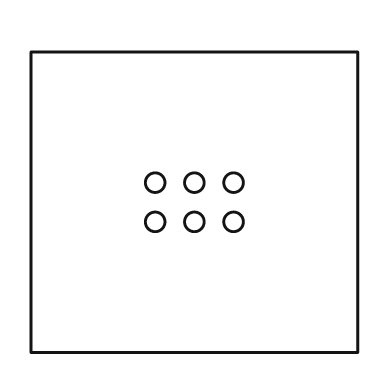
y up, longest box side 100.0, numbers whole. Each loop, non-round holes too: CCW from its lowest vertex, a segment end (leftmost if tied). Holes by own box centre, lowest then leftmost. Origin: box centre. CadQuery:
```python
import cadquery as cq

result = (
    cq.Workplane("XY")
    .moveTo(-50.0, -46.0)
    .lineTo(50.0, -46.0)
    .lineTo(50.0, 46.0)
    .lineTo(-50.0, 46.0)
    .close()
    .moveTo(-12.0, -6.0)
    .circle(3.0)
    .moveTo(0.0, -6.0)
    .circle(3.0)
    .moveTo(12.0, -6.0)
    .circle(3.0)
    .moveTo(-12.0, 6.0)
    .circle(3.0)
    .moveTo(0.0, 6.0)
    .circle(3.0)
    .moveTo(12.0, 6.0)
    .circle(3.0)
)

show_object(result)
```